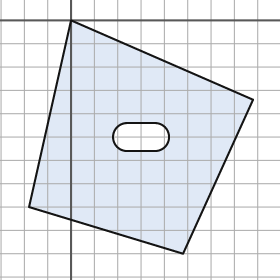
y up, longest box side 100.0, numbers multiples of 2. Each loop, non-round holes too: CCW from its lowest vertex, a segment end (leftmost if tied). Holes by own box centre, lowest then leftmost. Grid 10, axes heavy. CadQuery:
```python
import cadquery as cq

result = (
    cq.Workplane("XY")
    .moveTo(48.0, -100.0)
    .lineTo(78.0, -34.0)
    .lineTo(0.0, 0.0)
    .lineTo(-18.0, -80.0)
    .close()
    .moveTo(24.0, -56.0)
    .lineTo(36.0, -56.0)
    .threePointArc((42.0, -50.0), (36.0, -44.0))
    .lineTo(24.0, -44.0)
    .threePointArc((18.0, -50.0), (24.0, -56.0))
    .close()
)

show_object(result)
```